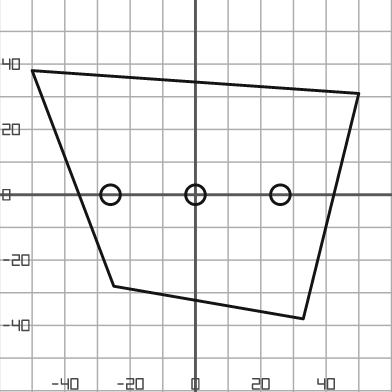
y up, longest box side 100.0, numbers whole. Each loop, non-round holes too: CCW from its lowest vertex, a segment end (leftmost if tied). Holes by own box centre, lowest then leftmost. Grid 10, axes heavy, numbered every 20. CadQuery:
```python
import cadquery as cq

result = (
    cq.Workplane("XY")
    .moveTo(33.0, -38.0)
    .lineTo(50.0, 31.0)
    .lineTo(-50.0, 38.0)
    .lineTo(-25.0, -28.0)
    .close()
    .moveTo(-26.0, 0.0)
    .circle(3.0)
    .moveTo(0.0, 0.0)
    .circle(3.0)
    .moveTo(26.0, 0.0)
    .circle(3.0)
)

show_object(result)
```